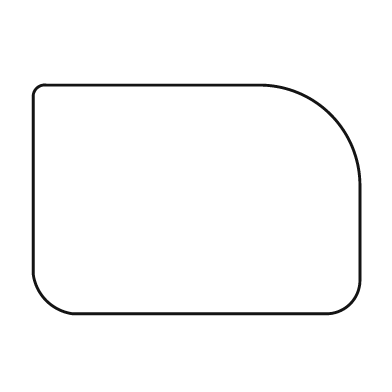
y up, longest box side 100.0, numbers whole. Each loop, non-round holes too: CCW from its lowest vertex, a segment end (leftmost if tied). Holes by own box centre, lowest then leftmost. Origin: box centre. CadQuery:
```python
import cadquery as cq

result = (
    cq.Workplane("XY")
    .moveTo(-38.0, -35.0)
    .lineTo(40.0, -35.0)
    .threePointArc((47.0, -32.0), (50.0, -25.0))
    .lineTo(50.0, 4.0)
    .threePointArc((41.0, 26.0), (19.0, 35.0))
    .lineTo(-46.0, 35.0)
    .threePointArc((-49.0, 34.0), (-50.0, 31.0))
    .lineTo(-50.0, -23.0)
    .threePointArc((-46.0, -31.0), (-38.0, -35.0))
    .close()
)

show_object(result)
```